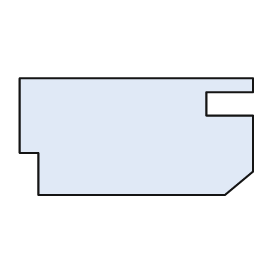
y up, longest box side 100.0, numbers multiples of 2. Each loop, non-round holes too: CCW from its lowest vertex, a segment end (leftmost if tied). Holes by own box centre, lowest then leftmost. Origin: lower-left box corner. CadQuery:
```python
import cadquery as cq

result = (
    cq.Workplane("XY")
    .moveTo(8.0, 0.0)
    .lineTo(88.0, 0.0)
    .lineTo(100.0, 10.0)
    .lineTo(100.0, 34.0)
    .lineTo(80.0, 34.0)
    .lineTo(80.0, 44.0)
    .lineTo(100.0, 44.0)
    .lineTo(100.0, 50.0)
    .lineTo(0.0, 50.0)
    .lineTo(0.0, 18.0)
    .lineTo(8.0, 18.0)
    .close()
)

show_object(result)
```